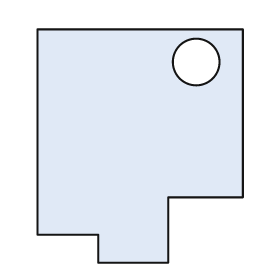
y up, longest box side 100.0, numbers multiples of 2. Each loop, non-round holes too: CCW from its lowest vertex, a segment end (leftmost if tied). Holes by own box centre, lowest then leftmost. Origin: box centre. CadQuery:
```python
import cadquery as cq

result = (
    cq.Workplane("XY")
    .moveTo(-18.0, -50.0)
    .lineTo(12.0, -50.0)
    .lineTo(12.0, -22.0)
    .lineTo(44.0, -22.0)
    .lineTo(44.0, 50.0)
    .lineTo(-44.0, 50.0)
    .lineTo(-44.0, -38.0)
    .lineTo(-18.0, -38.0)
    .close()
    .moveTo(24.0, 36.0)
    .circle(10.0)
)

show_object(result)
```